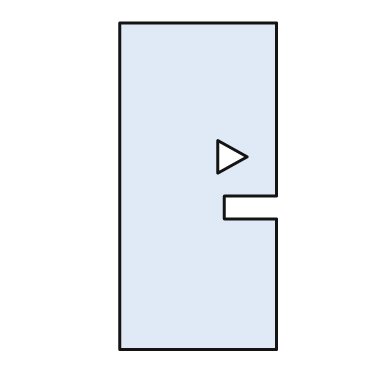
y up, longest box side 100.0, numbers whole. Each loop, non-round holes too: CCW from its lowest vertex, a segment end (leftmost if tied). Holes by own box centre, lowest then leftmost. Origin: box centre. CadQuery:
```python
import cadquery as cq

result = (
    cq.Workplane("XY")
    .moveTo(-24.0, -50.0)
    .lineTo(24.0, -50.0)
    .lineTo(24.0, -10.0)
    .lineTo(8.0, -10.0)
    .lineTo(8.0, -3.0)
    .lineTo(24.0, -3.0)
    .lineTo(24.0, 50.0)
    .lineTo(-24.0, 50.0)
    .close()
    .moveTo(6.0, 4.0)
    .lineTo(15.0, 9.0)
    .lineTo(6.0, 14.0)
    .close()
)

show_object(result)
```